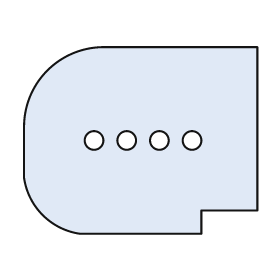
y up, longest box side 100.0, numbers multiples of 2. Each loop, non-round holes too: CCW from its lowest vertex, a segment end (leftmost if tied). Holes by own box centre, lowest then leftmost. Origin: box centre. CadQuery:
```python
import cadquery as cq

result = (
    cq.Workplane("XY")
    .moveTo(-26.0, -40.0)
    .lineTo(26.0, -40.0)
    .lineTo(26.0, -30.0)
    .lineTo(50.0, -30.0)
    .lineTo(50.0, 40.0)
    .lineTo(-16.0, 40.0)
    .threePointArc((-40.0, 30.0), (-50.0, 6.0))
    .lineTo(-50.0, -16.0)
    .threePointArc((-42.0, -32.0), (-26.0, -40.0))
    .close()
    .moveTo(-20.0, 0.0)
    .circle(4.0)
    .moveTo(-6.0, 0.0)
    .circle(4.0)
    .moveTo(8.0, 0.0)
    .circle(4.0)
    .moveTo(22.0, 0.0)
    .circle(4.0)
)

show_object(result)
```